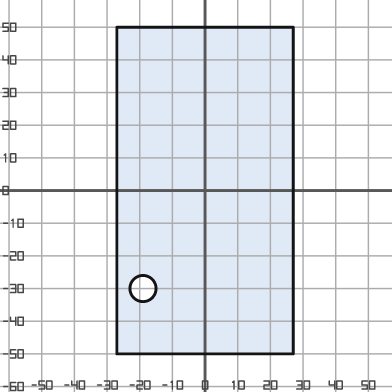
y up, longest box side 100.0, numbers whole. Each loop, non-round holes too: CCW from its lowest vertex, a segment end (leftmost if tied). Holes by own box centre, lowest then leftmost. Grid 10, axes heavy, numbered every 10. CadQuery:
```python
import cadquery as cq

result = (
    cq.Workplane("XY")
    .moveTo(-27.0, -50.0)
    .lineTo(27.0, -50.0)
    .lineTo(27.0, 50.0)
    .lineTo(-27.0, 50.0)
    .close()
    .moveTo(-19.0, -30.0)
    .circle(4.0)
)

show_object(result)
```